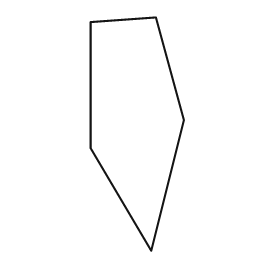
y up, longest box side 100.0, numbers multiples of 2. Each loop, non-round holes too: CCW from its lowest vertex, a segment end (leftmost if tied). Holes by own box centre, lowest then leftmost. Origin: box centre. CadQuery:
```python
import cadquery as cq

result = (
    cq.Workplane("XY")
    .moveTo(6.0, -50.0)
    .lineTo(20.0, 6.0)
    .lineTo(8.0, 50.0)
    .lineTo(-20.0, 48.0)
    .lineTo(-20.0, -6.0)
    .close()
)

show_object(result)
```